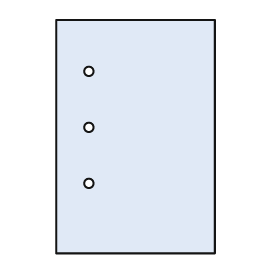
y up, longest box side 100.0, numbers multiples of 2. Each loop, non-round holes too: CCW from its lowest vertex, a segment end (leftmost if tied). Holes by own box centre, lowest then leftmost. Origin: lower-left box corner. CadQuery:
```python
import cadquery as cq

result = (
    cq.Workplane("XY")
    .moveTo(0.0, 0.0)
    .lineTo(68.0, 0.0)
    .lineTo(68.0, 100.0)
    .lineTo(0.0, 100.0)
    .close()
    .moveTo(14.0, 30.0)
    .circle(2.0)
    .moveTo(14.0, 54.0)
    .circle(2.0)
    .moveTo(14.0, 78.0)
    .circle(2.0)
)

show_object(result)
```